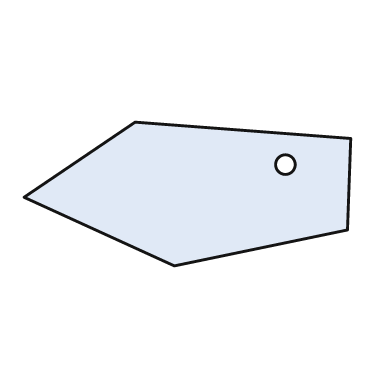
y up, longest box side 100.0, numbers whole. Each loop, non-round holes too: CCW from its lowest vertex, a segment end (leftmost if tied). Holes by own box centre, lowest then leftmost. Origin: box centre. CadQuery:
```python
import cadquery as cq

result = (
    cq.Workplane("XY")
    .moveTo(-4.0, -22.0)
    .lineTo(49.0, -11.0)
    .lineTo(50.0, 17.0)
    .lineTo(-16.0, 22.0)
    .lineTo(-50.0, -1.0)
    .close()
    .moveTo(30.0, 9.0)
    .circle(3.0)
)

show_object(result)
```